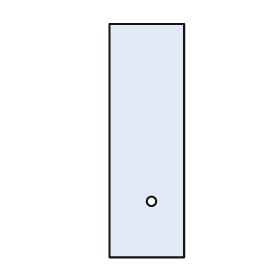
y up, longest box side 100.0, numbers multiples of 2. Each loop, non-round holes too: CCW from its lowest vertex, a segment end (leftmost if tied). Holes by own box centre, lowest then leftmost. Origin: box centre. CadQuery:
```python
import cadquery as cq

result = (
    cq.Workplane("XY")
    .moveTo(-16.0, -50.0)
    .lineTo(16.0, -50.0)
    .lineTo(16.0, 50.0)
    .lineTo(-16.0, 50.0)
    .close()
    .moveTo(2.0, -26.0)
    .circle(2.0)
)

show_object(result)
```